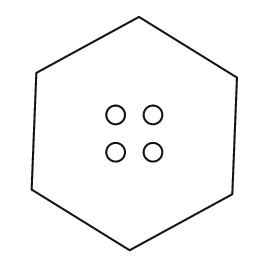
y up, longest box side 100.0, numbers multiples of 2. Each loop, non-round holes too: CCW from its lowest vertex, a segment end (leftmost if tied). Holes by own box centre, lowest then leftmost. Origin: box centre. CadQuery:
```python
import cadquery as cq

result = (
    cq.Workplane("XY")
    .moveTo(-2.0, -50.0)
    .lineTo(42.0, -26.0)
    .lineTo(44.0, 24.0)
    .lineTo(2.0, 50.0)
    .lineTo(-42.0, 26.0)
    .lineTo(-44.0, -24.0)
    .close()
    .moveTo(-8.0, -8.0)
    .circle(4.0)
    .moveTo(8.0, -8.0)
    .circle(4.0)
    .moveTo(-8.0, 8.0)
    .circle(4.0)
    .moveTo(8.0, 8.0)
    .circle(4.0)
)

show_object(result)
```